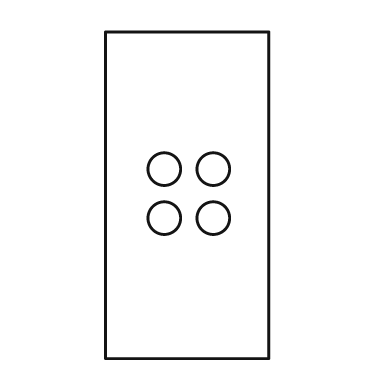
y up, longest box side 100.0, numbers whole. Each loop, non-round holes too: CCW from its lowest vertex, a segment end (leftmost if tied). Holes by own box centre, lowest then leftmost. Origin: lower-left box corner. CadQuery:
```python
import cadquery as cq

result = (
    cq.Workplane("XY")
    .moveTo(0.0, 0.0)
    .lineTo(50.0, 0.0)
    .lineTo(50.0, 100.0)
    .lineTo(0.0, 100.0)
    .close()
    .moveTo(18.0, 43.0)
    .circle(5.0)
    .moveTo(33.0, 43.0)
    .circle(5.0)
    .moveTo(18.0, 58.0)
    .circle(5.0)
    .moveTo(33.0, 58.0)
    .circle(5.0)
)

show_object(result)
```